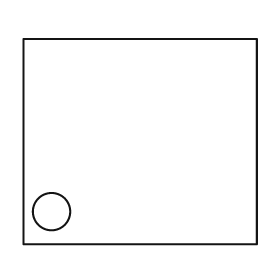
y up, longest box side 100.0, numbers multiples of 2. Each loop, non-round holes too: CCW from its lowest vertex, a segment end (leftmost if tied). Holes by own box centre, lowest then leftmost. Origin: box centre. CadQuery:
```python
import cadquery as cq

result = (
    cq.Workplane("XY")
    .moveTo(-50.0, -44.0)
    .lineTo(50.0, -44.0)
    .lineTo(50.0, 44.0)
    .lineTo(-50.0, 44.0)
    .close()
    .moveTo(-38.0, -30.0)
    .circle(8.0)
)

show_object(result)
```